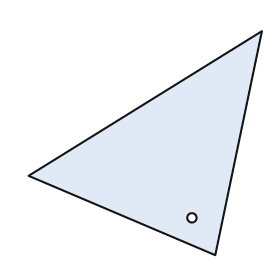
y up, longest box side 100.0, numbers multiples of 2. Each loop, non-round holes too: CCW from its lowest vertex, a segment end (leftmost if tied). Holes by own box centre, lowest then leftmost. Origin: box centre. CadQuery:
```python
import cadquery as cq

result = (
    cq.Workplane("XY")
    .moveTo(30.0, -48.0)
    .lineTo(50.0, 48.0)
    .lineTo(-50.0, -14.0)
    .close()
    .moveTo(20.0, -32.0)
    .circle(2.0)
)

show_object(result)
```